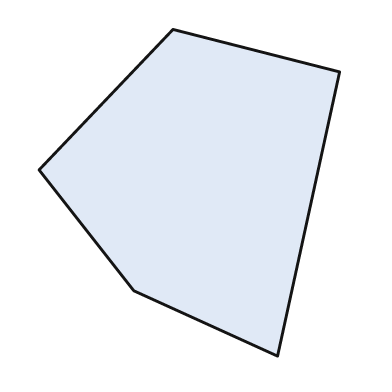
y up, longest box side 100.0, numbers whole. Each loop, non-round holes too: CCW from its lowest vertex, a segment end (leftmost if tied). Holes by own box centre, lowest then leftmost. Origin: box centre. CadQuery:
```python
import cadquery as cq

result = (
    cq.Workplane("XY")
    .moveTo(27.0, -50.0)
    .lineTo(46.0, 37.0)
    .lineTo(-5.0, 50.0)
    .lineTo(-46.0, 7.0)
    .lineTo(-17.0, -30.0)
    .close()
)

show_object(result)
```